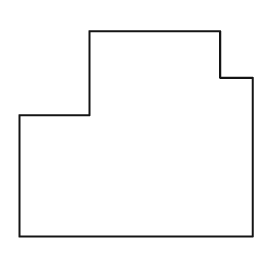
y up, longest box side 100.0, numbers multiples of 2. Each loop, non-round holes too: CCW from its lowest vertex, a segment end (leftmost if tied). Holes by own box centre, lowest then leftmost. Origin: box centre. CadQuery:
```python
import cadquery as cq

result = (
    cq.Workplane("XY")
    .moveTo(-50.0, -44.0)
    .lineTo(50.0, -44.0)
    .lineTo(50.0, 24.0)
    .lineTo(36.0, 24.0)
    .lineTo(36.0, 44.0)
    .lineTo(-20.0, 44.0)
    .lineTo(-20.0, 8.0)
    .lineTo(-50.0, 8.0)
    .close()
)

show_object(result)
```